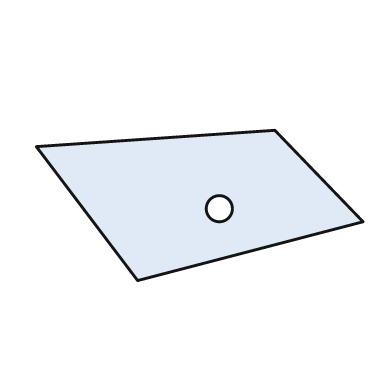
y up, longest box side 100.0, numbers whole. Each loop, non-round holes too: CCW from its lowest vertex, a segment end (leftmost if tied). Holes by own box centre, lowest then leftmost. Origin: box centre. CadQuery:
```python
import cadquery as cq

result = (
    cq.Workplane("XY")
    .moveTo(-19.0, -23.0)
    .lineTo(50.0, -5.0)
    .lineTo(23.0, 23.0)
    .lineTo(-50.0, 18.0)
    .close()
    .moveTo(6.0, -1.0)
    .circle(4.0)
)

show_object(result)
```